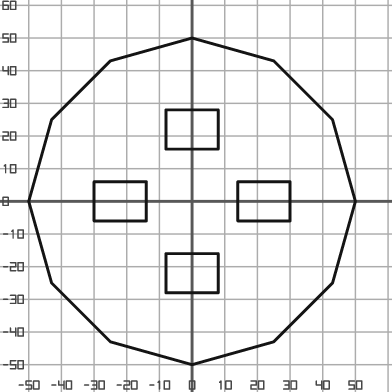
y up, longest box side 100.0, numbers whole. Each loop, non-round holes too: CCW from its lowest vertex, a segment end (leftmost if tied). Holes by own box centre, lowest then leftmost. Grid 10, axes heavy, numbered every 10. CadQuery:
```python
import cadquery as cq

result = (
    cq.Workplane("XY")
    .moveTo(0.0, -50.0)
    .lineTo(25.0, -43.0)
    .lineTo(43.0, -25.0)
    .lineTo(50.0, 0.0)
    .lineTo(43.0, 25.0)
    .lineTo(25.0, 43.0)
    .lineTo(0.0, 50.0)
    .lineTo(-25.0, 43.0)
    .lineTo(-43.0, 25.0)
    .lineTo(-50.0, 0.0)
    .lineTo(-43.0, -25.0)
    .lineTo(-25.0, -43.0)
    .close()
    .moveTo(-8.0, -28.0)
    .lineTo(8.0, -28.0)
    .lineTo(8.0, -16.0)
    .lineTo(-8.0, -16.0)
    .close()
    .moveTo(-30.0, -6.0)
    .lineTo(-14.0, -6.0)
    .lineTo(-14.0, 6.0)
    .lineTo(-30.0, 6.0)
    .close()
    .moveTo(14.0, -6.0)
    .lineTo(30.0, -6.0)
    .lineTo(30.0, 6.0)
    .lineTo(14.0, 6.0)
    .close()
    .moveTo(-8.0, 16.0)
    .lineTo(8.0, 16.0)
    .lineTo(8.0, 28.0)
    .lineTo(-8.0, 28.0)
    .close()
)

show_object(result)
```